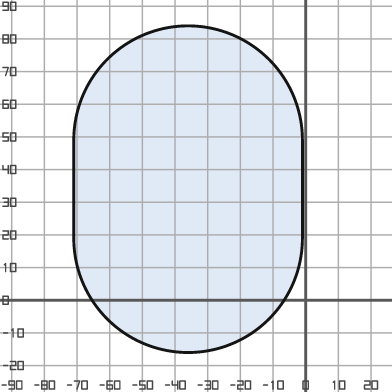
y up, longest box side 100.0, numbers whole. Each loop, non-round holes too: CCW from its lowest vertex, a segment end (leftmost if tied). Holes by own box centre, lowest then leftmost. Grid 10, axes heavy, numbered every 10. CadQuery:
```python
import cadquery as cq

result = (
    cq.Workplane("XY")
    .moveTo(-71.0, 19.0)
    .threePointArc((-36.0, -16.0), (-1.0, 19.0))
    .lineTo(-1.0, 49.0)
    .threePointArc((-36.0, 84.0), (-71.0, 49.0))
    .close()
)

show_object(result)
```